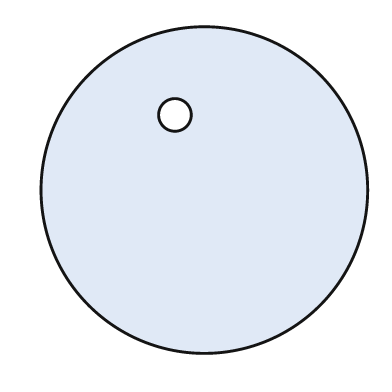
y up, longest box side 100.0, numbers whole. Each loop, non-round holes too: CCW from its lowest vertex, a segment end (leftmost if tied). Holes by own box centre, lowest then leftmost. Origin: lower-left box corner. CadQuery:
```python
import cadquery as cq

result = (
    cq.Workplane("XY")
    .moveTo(50.0, 50.0)
    .circle(50.0)
    .moveTo(41.0, 73.0)
    .circle(5.0)
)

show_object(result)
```